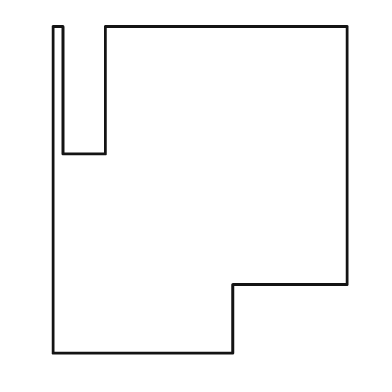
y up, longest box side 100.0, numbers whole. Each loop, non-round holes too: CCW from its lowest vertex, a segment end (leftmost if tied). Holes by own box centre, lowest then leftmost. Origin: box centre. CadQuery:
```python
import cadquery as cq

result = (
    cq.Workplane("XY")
    .moveTo(-45.0, -50.0)
    .lineTo(10.0, -50.0)
    .lineTo(10.0, -29.0)
    .lineTo(45.0, -29.0)
    .lineTo(45.0, 50.0)
    .lineTo(-29.0, 50.0)
    .lineTo(-29.0, 11.0)
    .lineTo(-42.0, 11.0)
    .lineTo(-42.0, 50.0)
    .lineTo(-45.0, 50.0)
    .close()
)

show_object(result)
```